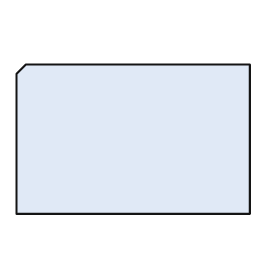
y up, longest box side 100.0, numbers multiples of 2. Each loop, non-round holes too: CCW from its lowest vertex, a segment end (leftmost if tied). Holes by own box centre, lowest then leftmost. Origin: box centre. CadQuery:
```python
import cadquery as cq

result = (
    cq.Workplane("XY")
    .moveTo(-50.0, -32.0)
    .lineTo(50.0, -32.0)
    .lineTo(50.0, 32.0)
    .lineTo(-46.0, 32.0)
    .lineTo(-50.0, 28.0)
    .close()
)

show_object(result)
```